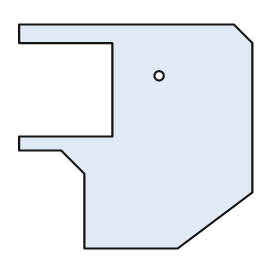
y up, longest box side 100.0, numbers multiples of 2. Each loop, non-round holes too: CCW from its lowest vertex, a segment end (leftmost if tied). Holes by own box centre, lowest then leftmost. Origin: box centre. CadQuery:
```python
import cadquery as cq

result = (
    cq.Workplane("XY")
    .moveTo(-22.0, -48.0)
    .lineTo(18.0, -48.0)
    .lineTo(50.0, -24.0)
    .lineTo(50.0, 40.0)
    .lineTo(42.0, 48.0)
    .lineTo(-50.0, 48.0)
    .lineTo(-50.0, 40.0)
    .lineTo(-10.0, 40.0)
    .lineTo(-10.0, 0.0)
    .lineTo(-50.0, 0.0)
    .lineTo(-50.0, -6.0)
    .lineTo(-32.0, -6.0)
    .lineTo(-22.0, -16.0)
    .close()
    .moveTo(10.0, 26.0)
    .circle(2.0)
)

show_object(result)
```